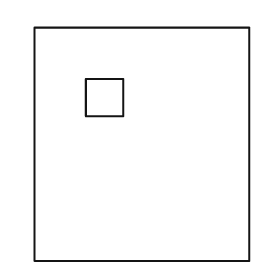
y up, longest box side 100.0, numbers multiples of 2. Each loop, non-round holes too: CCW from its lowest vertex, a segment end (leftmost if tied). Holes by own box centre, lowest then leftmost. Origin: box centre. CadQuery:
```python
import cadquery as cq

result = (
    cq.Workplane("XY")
    .moveTo(-46.0, -50.0)
    .lineTo(46.0, -50.0)
    .lineTo(46.0, 50.0)
    .lineTo(-46.0, 50.0)
    .close()
    .moveTo(-24.0, 12.0)
    .lineTo(-8.0, 12.0)
    .lineTo(-8.0, 28.0)
    .lineTo(-24.0, 28.0)
    .close()
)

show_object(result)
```